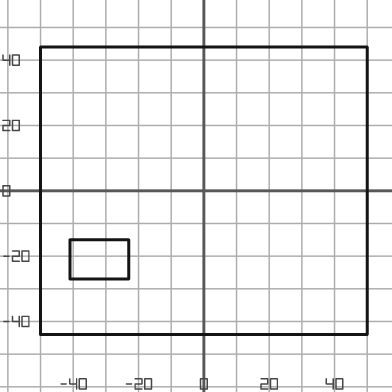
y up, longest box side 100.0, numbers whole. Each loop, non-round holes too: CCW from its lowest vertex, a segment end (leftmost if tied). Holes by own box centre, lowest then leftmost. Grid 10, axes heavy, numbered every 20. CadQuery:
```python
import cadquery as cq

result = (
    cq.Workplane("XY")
    .moveTo(-50.0, -44.0)
    .lineTo(50.0, -44.0)
    .lineTo(50.0, 44.0)
    .lineTo(-50.0, 44.0)
    .close()
    .moveTo(-41.0, -27.0)
    .lineTo(-23.0, -27.0)
    .lineTo(-23.0, -15.0)
    .lineTo(-41.0, -15.0)
    .close()
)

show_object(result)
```